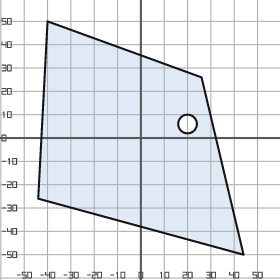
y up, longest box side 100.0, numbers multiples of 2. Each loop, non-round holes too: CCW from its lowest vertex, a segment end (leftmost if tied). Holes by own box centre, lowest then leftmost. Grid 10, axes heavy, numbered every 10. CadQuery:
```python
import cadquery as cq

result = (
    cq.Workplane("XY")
    .moveTo(44.0, -50.0)
    .lineTo(26.0, 26.0)
    .lineTo(-40.0, 50.0)
    .lineTo(-44.0, -26.0)
    .close()
    .moveTo(20.0, 6.0)
    .circle(4.0)
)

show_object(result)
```